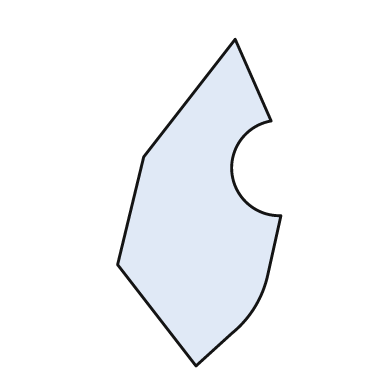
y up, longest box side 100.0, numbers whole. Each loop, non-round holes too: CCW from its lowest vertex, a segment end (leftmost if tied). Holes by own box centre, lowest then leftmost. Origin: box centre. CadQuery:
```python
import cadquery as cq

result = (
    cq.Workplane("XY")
    .moveTo(-1.0, -50.0)
    .lineTo(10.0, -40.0)
    .threePointArc((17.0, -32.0), (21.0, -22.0))
    .lineTo(25.0, -4.0)
    .threePointArc((10.0, 9.0), (22.0, 25.0))
    .lineTo(11.0, 50.0)
    .lineTo(-17.0, 14.0)
    .lineTo(-25.0, -19.0)
    .close()
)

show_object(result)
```